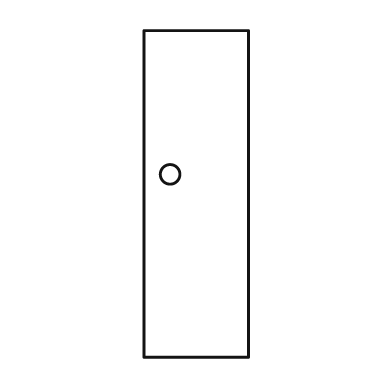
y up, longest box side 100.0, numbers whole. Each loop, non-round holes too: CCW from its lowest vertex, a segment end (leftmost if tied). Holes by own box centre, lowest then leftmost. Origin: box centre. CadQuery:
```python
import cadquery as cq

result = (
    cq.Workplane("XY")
    .moveTo(-16.0, -50.0)
    .lineTo(16.0, -50.0)
    .lineTo(16.0, 50.0)
    .lineTo(-16.0, 50.0)
    .close()
    .moveTo(-8.0, 6.0)
    .circle(3.0)
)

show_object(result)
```